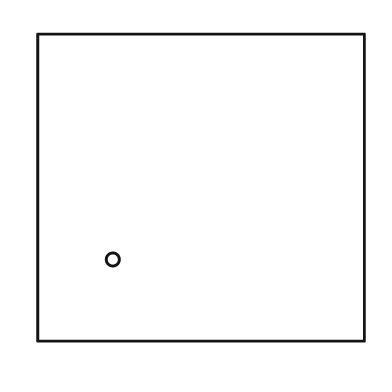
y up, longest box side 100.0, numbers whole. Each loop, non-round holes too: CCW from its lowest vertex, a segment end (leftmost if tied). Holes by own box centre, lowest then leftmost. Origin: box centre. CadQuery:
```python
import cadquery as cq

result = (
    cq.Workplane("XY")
    .moveTo(-50.0, -47.0)
    .lineTo(50.0, -47.0)
    .lineTo(50.0, 47.0)
    .lineTo(-50.0, 47.0)
    .close()
    .moveTo(-27.0, -22.0)
    .circle(2.0)
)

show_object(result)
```